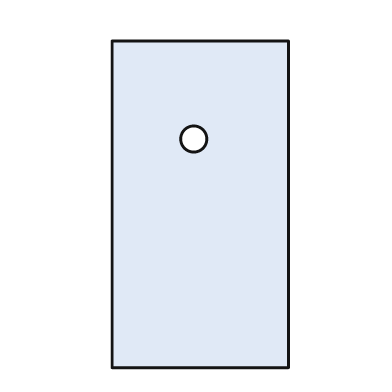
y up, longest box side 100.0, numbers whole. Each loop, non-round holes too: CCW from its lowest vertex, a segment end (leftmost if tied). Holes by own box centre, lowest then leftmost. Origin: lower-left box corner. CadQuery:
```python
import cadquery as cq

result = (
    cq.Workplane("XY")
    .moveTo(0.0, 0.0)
    .lineTo(54.0, 0.0)
    .lineTo(54.0, 100.0)
    .lineTo(0.0, 100.0)
    .close()
    .moveTo(25.0, 70.0)
    .circle(4.0)
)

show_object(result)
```